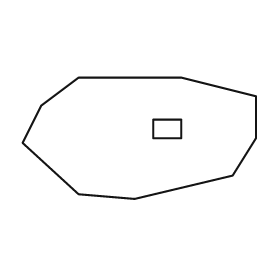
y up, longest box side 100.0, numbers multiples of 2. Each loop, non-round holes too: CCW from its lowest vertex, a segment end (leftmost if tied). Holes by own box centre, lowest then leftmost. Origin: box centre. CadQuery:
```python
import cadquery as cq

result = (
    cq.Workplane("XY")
    .moveTo(-2.0, -26.0)
    .lineTo(40.0, -16.0)
    .lineTo(50.0, 0.0)
    .lineTo(50.0, 18.0)
    .lineTo(18.0, 26.0)
    .lineTo(-26.0, 26.0)
    .lineTo(-42.0, 14.0)
    .lineTo(-50.0, -2.0)
    .lineTo(-26.0, -24.0)
    .close()
    .moveTo(6.0, 0.0)
    .lineTo(18.0, 0.0)
    .lineTo(18.0, 8.0)
    .lineTo(6.0, 8.0)
    .close()
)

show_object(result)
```